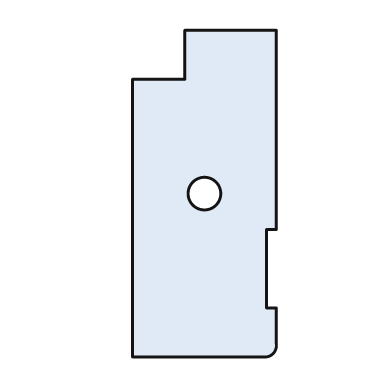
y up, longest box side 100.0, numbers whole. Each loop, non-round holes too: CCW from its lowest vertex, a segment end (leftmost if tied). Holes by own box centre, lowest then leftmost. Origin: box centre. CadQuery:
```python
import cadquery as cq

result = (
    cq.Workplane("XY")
    .moveTo(-22.0, -50.0)
    .lineTo(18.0, -50.0)
    .threePointArc((21.0, -49.0), (22.0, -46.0))
    .lineTo(22.0, -35.0)
    .lineTo(19.0, -35.0)
    .lineTo(19.0, -11.0)
    .lineTo(22.0, -11.0)
    .lineTo(22.0, 50.0)
    .lineTo(-6.0, 50.0)
    .lineTo(-6.0, 35.0)
    .lineTo(-22.0, 35.0)
    .close()
    .moveTo(0.0, 0.0)
    .circle(5.0)
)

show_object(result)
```